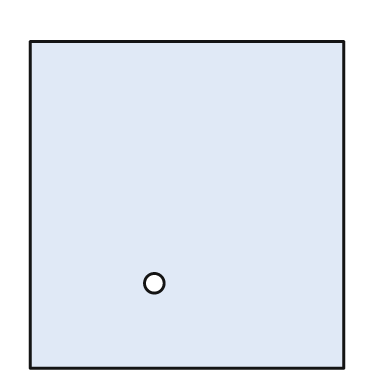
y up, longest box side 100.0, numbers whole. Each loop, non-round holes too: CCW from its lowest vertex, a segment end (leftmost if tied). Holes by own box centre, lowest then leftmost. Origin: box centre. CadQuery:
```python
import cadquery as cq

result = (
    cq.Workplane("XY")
    .moveTo(-48.0, -50.0)
    .lineTo(48.0, -50.0)
    .lineTo(48.0, 50.0)
    .lineTo(-48.0, 50.0)
    .close()
    .moveTo(-10.0, -24.0)
    .circle(3.0)
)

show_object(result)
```